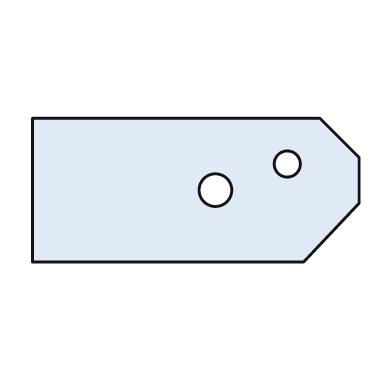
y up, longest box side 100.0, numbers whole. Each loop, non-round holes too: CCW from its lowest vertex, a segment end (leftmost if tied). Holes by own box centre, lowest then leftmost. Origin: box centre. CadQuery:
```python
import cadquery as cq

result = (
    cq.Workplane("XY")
    .moveTo(-50.0, -22.0)
    .lineTo(33.0, -22.0)
    .lineTo(50.0, -4.0)
    .lineTo(50.0, 10.0)
    .lineTo(38.0, 22.0)
    .lineTo(-50.0, 22.0)
    .close()
    .moveTo(6.0, 0.0)
    .circle(5.0)
    .moveTo(28.0, 8.0)
    .circle(4.0)
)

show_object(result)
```